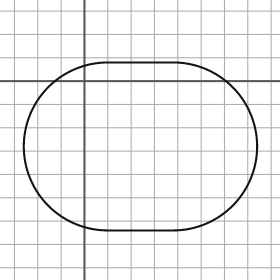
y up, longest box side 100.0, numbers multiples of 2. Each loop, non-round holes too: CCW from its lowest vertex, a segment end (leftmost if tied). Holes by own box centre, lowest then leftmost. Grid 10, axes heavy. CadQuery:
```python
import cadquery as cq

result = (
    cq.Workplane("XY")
    .moveTo(10.0, -64.0)
    .lineTo(38.0, -64.0)
    .threePointArc((74.0, -28.0), (38.0, 8.0))
    .lineTo(10.0, 8.0)
    .threePointArc((-26.0, -28.0), (10.0, -64.0))
    .close()
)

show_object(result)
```